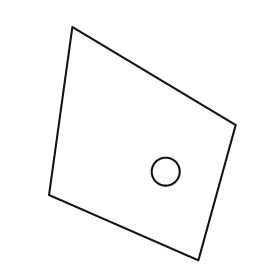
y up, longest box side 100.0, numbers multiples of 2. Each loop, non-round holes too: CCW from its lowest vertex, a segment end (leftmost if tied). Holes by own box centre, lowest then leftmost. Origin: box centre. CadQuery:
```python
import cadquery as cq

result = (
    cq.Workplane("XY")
    .moveTo(24.0, -50.0)
    .lineTo(40.0, 8.0)
    .lineTo(-30.0, 50.0)
    .lineTo(-40.0, -22.0)
    .close()
    .moveTo(10.0, -12.0)
    .circle(6.0)
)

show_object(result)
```